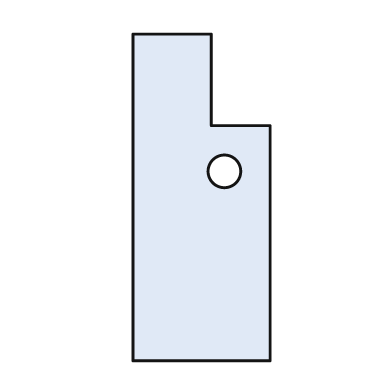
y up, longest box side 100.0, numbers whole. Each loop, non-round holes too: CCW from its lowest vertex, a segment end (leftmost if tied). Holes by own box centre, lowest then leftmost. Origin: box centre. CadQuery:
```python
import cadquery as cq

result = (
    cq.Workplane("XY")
    .moveTo(-21.0, -50.0)
    .lineTo(21.0, -50.0)
    .lineTo(21.0, 22.0)
    .lineTo(3.0, 22.0)
    .lineTo(3.0, 50.0)
    .lineTo(-21.0, 50.0)
    .close()
    .moveTo(7.0, 8.0)
    .circle(5.0)
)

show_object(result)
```